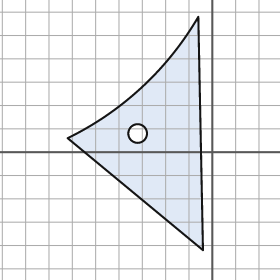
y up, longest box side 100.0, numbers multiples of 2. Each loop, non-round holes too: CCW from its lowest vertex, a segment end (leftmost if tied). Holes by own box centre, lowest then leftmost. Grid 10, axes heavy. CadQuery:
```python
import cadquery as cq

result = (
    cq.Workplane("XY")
    .moveTo(-4.0, -42.0)
    .lineTo(-6.0, 58.0)
    .threePointArc((-30.0, 28.0), (-62.0, 6.0))
    .close()
    .moveTo(-32.0, 8.0)
    .circle(4.0)
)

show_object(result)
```